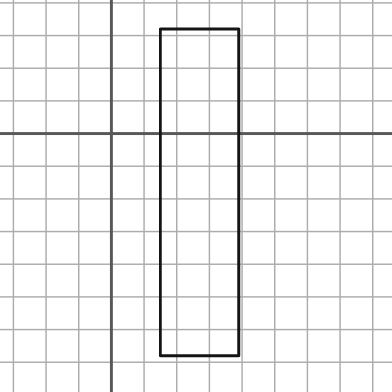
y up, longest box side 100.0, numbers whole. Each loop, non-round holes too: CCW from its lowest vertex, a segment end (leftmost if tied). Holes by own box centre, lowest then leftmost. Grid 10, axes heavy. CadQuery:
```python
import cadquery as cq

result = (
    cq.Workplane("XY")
    .moveTo(15.0, -68.0)
    .lineTo(39.0, -68.0)
    .lineTo(39.0, 32.0)
    .lineTo(15.0, 32.0)
    .close()
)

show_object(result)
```